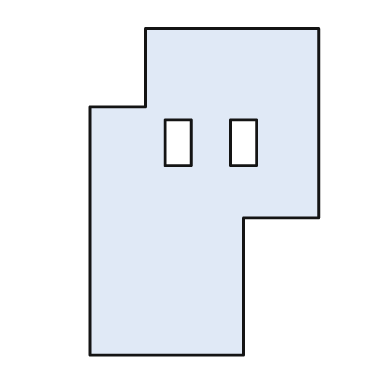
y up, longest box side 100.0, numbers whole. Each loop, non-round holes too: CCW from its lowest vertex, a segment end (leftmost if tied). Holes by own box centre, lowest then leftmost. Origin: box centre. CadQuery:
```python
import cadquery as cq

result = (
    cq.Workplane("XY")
    .moveTo(-35.0, -50.0)
    .lineTo(12.0, -50.0)
    .lineTo(12.0, -8.0)
    .lineTo(35.0, -8.0)
    .lineTo(35.0, 50.0)
    .lineTo(-18.0, 50.0)
    .lineTo(-18.0, 26.0)
    .lineTo(-35.0, 26.0)
    .close()
    .moveTo(-12.0, 8.0)
    .lineTo(-4.0, 8.0)
    .lineTo(-4.0, 22.0)
    .lineTo(-12.0, 22.0)
    .close()
    .moveTo(8.0, 8.0)
    .lineTo(16.0, 8.0)
    .lineTo(16.0, 22.0)
    .lineTo(8.0, 22.0)
    .close()
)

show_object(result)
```